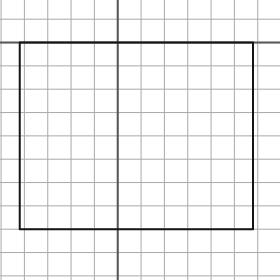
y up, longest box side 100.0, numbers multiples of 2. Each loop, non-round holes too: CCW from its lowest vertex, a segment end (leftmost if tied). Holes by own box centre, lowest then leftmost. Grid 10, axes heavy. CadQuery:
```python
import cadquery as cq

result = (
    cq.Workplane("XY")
    .moveTo(-42.0, -80.0)
    .lineTo(58.0, -80.0)
    .lineTo(58.0, 0.0)
    .lineTo(-42.0, 0.0)
    .close()
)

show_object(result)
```